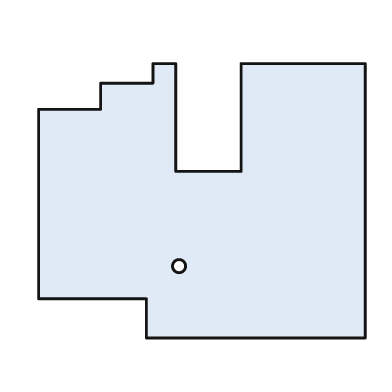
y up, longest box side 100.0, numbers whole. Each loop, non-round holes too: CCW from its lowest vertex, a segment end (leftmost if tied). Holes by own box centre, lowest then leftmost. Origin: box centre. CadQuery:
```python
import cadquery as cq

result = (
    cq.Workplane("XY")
    .moveTo(-17.0, -42.0)
    .lineTo(50.0, -42.0)
    .lineTo(50.0, 42.0)
    .lineTo(12.0, 42.0)
    .lineTo(12.0, 9.0)
    .lineTo(-8.0, 9.0)
    .lineTo(-8.0, 42.0)
    .lineTo(-15.0, 42.0)
    .lineTo(-15.0, 36.0)
    .lineTo(-31.0, 36.0)
    .lineTo(-31.0, 28.0)
    .lineTo(-50.0, 28.0)
    .lineTo(-50.0, -30.0)
    .lineTo(-17.0, -30.0)
    .close()
    .moveTo(-7.0, -20.0)
    .circle(2.0)
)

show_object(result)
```